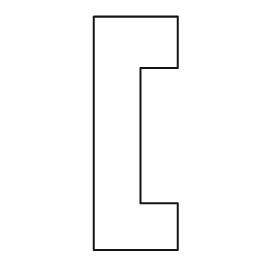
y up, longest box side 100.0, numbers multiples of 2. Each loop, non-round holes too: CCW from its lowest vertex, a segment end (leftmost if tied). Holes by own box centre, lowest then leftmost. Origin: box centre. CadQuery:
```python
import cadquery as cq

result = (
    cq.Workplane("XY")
    .moveTo(-18.0, -50.0)
    .lineTo(18.0, -50.0)
    .lineTo(18.0, -30.0)
    .lineTo(2.0, -30.0)
    .lineTo(2.0, 28.0)
    .lineTo(18.0, 28.0)
    .lineTo(18.0, 50.0)
    .lineTo(-18.0, 50.0)
    .close()
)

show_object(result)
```